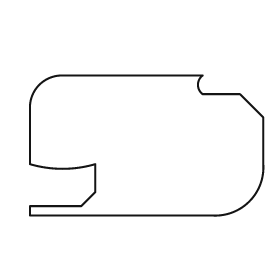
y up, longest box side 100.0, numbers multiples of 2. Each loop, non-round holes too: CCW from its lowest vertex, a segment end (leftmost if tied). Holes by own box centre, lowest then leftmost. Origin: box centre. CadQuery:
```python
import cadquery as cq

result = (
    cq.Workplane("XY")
    .moveTo(-50.0, -30.0)
    .lineTo(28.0, -30.0)
    .threePointArc((44.0, -24.0), (50.0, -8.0))
    .lineTo(50.0, 12.0)
    .lineTo(40.0, 22.0)
    .lineTo(24.0, 22.0)
    .threePointArc((22.0, 26.0), (24.0, 30.0))
    .lineTo(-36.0, 30.0)
    .threePointArc((-46.0, 26.0), (-50.0, 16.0))
    .lineTo(-50.0, -8.0)
    .threePointArc((-36.0, -10.0), (-22.0, -8.0))
    .lineTo(-22.0, -20.0)
    .lineTo(-28.0, -26.0)
    .lineTo(-50.0, -26.0)
    .close()
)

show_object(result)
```